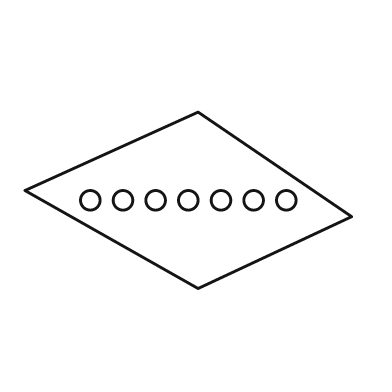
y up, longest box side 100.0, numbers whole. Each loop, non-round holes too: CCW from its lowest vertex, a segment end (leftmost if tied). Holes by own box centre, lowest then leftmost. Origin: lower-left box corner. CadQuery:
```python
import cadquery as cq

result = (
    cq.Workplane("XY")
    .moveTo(53.0, 0.0)
    .lineTo(100.0, 22.0)
    .lineTo(53.0, 54.0)
    .lineTo(0.0, 30.0)
    .close()
    .moveTo(20.0, 27.0)
    .circle(3.0)
    .moveTo(30.0, 27.0)
    .circle(3.0)
    .moveTo(40.0, 27.0)
    .circle(3.0)
    .moveTo(50.0, 27.0)
    .circle(3.0)
    .moveTo(60.0, 27.0)
    .circle(3.0)
    .moveTo(70.0, 27.0)
    .circle(3.0)
    .moveTo(80.0, 27.0)
    .circle(3.0)
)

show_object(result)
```